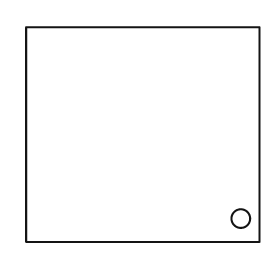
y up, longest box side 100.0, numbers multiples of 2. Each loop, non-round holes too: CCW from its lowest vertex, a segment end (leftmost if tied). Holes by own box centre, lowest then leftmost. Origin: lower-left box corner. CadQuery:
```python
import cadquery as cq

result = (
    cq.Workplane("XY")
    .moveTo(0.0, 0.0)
    .lineTo(100.0, 0.0)
    .lineTo(100.0, 92.0)
    .lineTo(0.0, 92.0)
    .close()
    .moveTo(92.0, 10.0)
    .circle(4.0)
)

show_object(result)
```